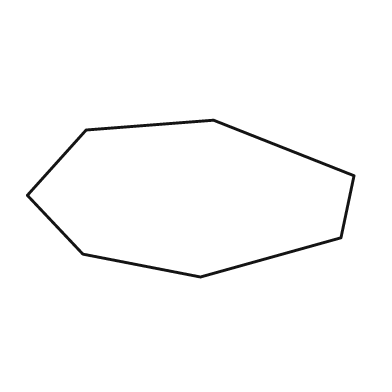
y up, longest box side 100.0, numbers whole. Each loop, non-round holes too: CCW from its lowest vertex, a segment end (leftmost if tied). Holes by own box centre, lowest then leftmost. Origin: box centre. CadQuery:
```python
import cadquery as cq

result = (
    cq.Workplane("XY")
    .moveTo(3.0, -24.0)
    .lineTo(46.0, -12.0)
    .lineTo(50.0, 7.0)
    .lineTo(7.0, 24.0)
    .lineTo(-32.0, 21.0)
    .lineTo(-50.0, 1.0)
    .lineTo(-33.0, -17.0)
    .close()
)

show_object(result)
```